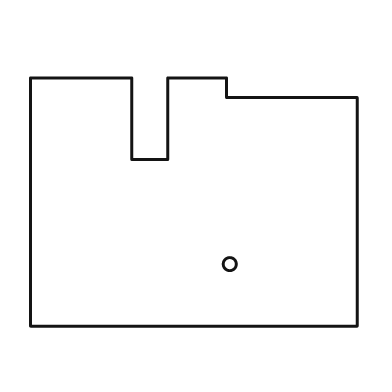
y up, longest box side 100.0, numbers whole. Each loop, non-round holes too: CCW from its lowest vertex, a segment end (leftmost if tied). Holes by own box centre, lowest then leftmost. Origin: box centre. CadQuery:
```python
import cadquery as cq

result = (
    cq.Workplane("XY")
    .moveTo(-50.0, -38.0)
    .lineTo(50.0, -38.0)
    .lineTo(50.0, 32.0)
    .lineTo(10.0, 32.0)
    .lineTo(10.0, 38.0)
    .lineTo(-8.0, 38.0)
    .lineTo(-8.0, 13.0)
    .lineTo(-19.0, 13.0)
    .lineTo(-19.0, 38.0)
    .lineTo(-50.0, 38.0)
    .close()
    .moveTo(11.0, -19.0)
    .circle(2.0)
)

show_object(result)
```